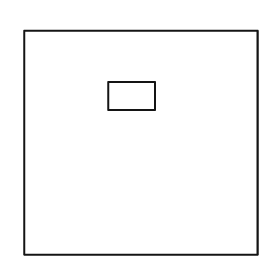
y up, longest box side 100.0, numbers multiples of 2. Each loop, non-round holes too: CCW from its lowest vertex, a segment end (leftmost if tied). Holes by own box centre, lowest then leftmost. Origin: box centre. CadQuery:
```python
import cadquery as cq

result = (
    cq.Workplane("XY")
    .moveTo(-50.0, -48.0)
    .lineTo(50.0, -48.0)
    .lineTo(50.0, 48.0)
    .lineTo(-50.0, 48.0)
    .close()
    .moveTo(-14.0, 14.0)
    .lineTo(6.0, 14.0)
    .lineTo(6.0, 26.0)
    .lineTo(-14.0, 26.0)
    .close()
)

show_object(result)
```